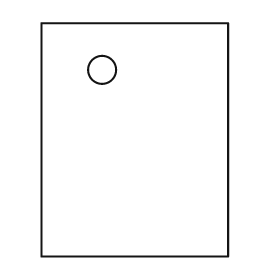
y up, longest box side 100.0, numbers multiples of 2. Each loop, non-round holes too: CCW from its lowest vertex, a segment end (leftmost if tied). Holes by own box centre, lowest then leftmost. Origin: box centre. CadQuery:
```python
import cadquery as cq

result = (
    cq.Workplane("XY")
    .moveTo(-40.0, -50.0)
    .lineTo(40.0, -50.0)
    .lineTo(40.0, 50.0)
    .lineTo(-40.0, 50.0)
    .close()
    .moveTo(-14.0, 30.0)
    .circle(6.0)
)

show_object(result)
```